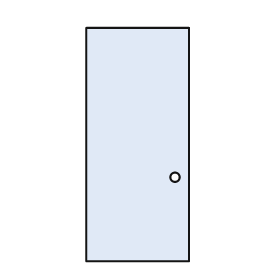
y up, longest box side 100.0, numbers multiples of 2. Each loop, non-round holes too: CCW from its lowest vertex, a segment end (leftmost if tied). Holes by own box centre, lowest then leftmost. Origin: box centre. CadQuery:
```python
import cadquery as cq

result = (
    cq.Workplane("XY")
    .moveTo(-22.0, -50.0)
    .lineTo(22.0, -50.0)
    .lineTo(22.0, 50.0)
    .lineTo(-22.0, 50.0)
    .close()
    .moveTo(16.0, -14.0)
    .circle(2.0)
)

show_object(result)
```